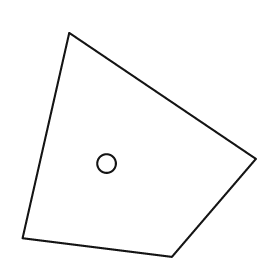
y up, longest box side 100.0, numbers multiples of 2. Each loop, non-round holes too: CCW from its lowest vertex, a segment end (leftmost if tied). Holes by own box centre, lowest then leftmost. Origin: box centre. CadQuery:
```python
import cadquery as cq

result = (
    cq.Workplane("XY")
    .moveTo(14.0, -48.0)
    .lineTo(50.0, -6.0)
    .lineTo(-30.0, 48.0)
    .lineTo(-50.0, -40.0)
    .close()
    .moveTo(-14.0, -8.0)
    .circle(4.0)
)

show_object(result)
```